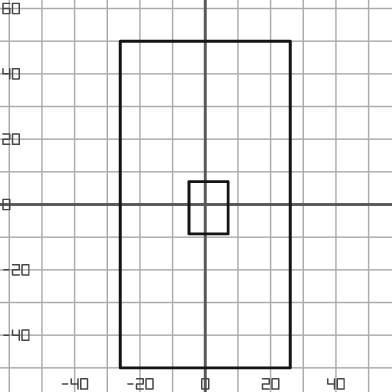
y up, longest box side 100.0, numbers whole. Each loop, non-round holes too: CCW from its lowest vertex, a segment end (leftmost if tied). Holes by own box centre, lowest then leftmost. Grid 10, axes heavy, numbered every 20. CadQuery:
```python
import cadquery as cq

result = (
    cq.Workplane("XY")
    .moveTo(-26.0, -50.0)
    .lineTo(26.0, -50.0)
    .lineTo(26.0, 50.0)
    .lineTo(-26.0, 50.0)
    .close()
    .moveTo(-5.0, -9.0)
    .lineTo(7.0, -9.0)
    .lineTo(7.0, 7.0)
    .lineTo(-5.0, 7.0)
    .close()
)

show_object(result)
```